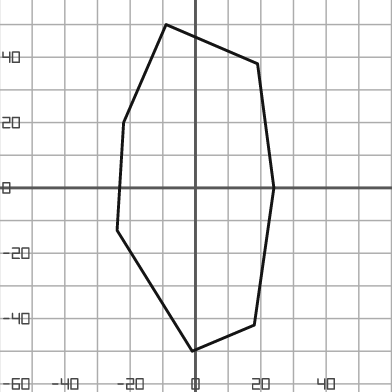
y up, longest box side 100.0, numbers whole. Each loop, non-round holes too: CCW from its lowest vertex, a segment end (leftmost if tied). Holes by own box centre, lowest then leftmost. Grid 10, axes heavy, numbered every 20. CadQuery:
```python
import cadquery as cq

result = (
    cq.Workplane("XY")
    .moveTo(-1.0, -50.0)
    .lineTo(18.0, -42.0)
    .lineTo(24.0, 0.0)
    .lineTo(19.0, 38.0)
    .lineTo(-9.0, 50.0)
    .lineTo(-22.0, 20.0)
    .lineTo(-24.0, -13.0)
    .close()
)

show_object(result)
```